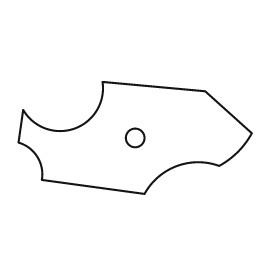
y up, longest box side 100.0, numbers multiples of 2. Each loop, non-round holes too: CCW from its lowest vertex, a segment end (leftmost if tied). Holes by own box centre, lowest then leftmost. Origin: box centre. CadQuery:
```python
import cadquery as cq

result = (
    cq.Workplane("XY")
    .moveTo(4.0, -24.0)
    .threePointArc((18.0, -12.0), (36.0, -12.0))
    .threePointArc((44.0, -6.0), (50.0, 2.0))
    .lineTo(30.0, 20.0)
    .lineTo(-14.0, 24.0)
    .threePointArc((-26.0, 4.0), (-48.0, 12.0))
    .lineTo(-50.0, -2.0)
    .threePointArc((-42.0, -8.0), (-40.0, -18.0))
    .close()
    .moveTo(0.0, 0.0)
    .circle(4.0)
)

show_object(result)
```